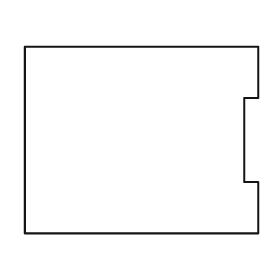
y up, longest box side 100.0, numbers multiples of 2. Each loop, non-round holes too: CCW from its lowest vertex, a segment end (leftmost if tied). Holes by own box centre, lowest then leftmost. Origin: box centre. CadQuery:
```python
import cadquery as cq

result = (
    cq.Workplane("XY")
    .moveTo(-50.0, -40.0)
    .lineTo(50.0, -40.0)
    .lineTo(50.0, -18.0)
    .lineTo(44.0, -18.0)
    .lineTo(44.0, 18.0)
    .lineTo(50.0, 18.0)
    .lineTo(50.0, 40.0)
    .lineTo(-50.0, 40.0)
    .close()
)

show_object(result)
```